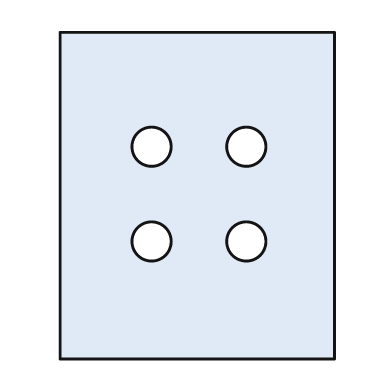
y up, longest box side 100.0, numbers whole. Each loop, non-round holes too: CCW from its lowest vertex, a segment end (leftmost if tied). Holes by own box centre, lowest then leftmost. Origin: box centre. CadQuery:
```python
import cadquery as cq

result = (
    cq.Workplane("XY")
    .moveTo(-42.0, -50.0)
    .lineTo(42.0, -50.0)
    .lineTo(42.0, 50.0)
    .lineTo(-42.0, 50.0)
    .close()
    .moveTo(-14.0, -14.0)
    .circle(6.0)
    .moveTo(15.0, -14.0)
    .circle(6.0)
    .moveTo(-14.0, 15.0)
    .circle(6.0)
    .moveTo(15.0, 15.0)
    .circle(6.0)
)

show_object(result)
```